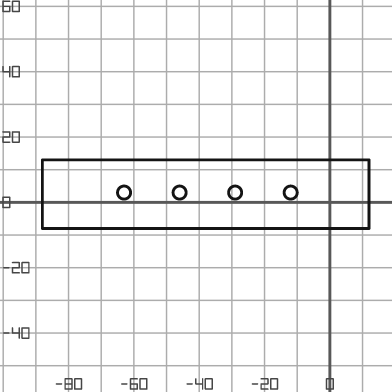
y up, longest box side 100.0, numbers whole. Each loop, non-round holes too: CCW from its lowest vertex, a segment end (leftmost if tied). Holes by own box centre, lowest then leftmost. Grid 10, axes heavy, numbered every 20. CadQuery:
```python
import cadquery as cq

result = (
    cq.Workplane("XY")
    .moveTo(-88.0, -8.0)
    .lineTo(12.0, -8.0)
    .lineTo(12.0, 13.0)
    .lineTo(-88.0, 13.0)
    .close()
    .moveTo(-63.0, 3.0)
    .circle(2.0)
    .moveTo(-46.0, 3.0)
    .circle(2.0)
    .moveTo(-29.0, 3.0)
    .circle(2.0)
    .moveTo(-12.0, 3.0)
    .circle(2.0)
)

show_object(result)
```